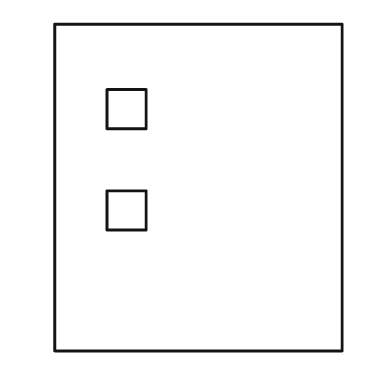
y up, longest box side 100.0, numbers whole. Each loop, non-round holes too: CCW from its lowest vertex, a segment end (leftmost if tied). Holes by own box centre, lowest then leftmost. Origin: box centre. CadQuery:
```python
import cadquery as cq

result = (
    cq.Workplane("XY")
    .moveTo(-44.0, -50.0)
    .lineTo(44.0, -50.0)
    .lineTo(44.0, 50.0)
    .lineTo(-44.0, 50.0)
    .close()
    .moveTo(-28.0, -13.0)
    .lineTo(-16.0, -13.0)
    .lineTo(-16.0, -1.0)
    .lineTo(-28.0, -1.0)
    .close()
    .moveTo(-28.0, 18.0)
    .lineTo(-16.0, 18.0)
    .lineTo(-16.0, 30.0)
    .lineTo(-28.0, 30.0)
    .close()
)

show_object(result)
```